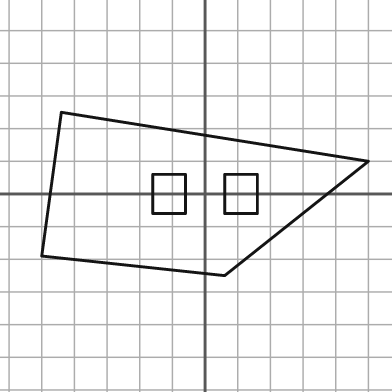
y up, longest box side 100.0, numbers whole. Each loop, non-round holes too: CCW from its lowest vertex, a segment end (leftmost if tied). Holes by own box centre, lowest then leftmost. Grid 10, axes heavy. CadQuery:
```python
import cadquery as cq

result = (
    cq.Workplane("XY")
    .moveTo(6.0, -25.0)
    .lineTo(50.0, 10.0)
    .lineTo(-44.0, 25.0)
    .lineTo(-50.0, -19.0)
    .close()
    .moveTo(-16.0, -6.0)
    .lineTo(-6.0, -6.0)
    .lineTo(-6.0, 6.0)
    .lineTo(-16.0, 6.0)
    .close()
    .moveTo(6.0, -6.0)
    .lineTo(16.0, -6.0)
    .lineTo(16.0, 6.0)
    .lineTo(6.0, 6.0)
    .close()
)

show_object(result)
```